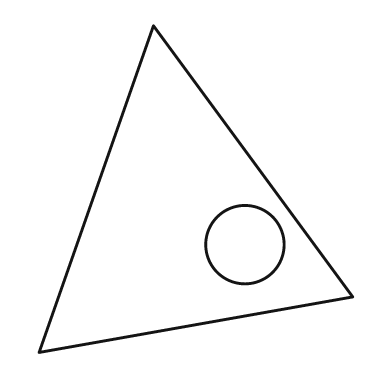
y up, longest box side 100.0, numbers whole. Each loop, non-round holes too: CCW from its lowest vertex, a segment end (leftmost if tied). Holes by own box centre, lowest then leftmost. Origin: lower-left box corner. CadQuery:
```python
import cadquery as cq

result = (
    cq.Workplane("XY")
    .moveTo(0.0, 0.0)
    .lineTo(96.0, 17.0)
    .lineTo(35.0, 100.0)
    .close()
    .moveTo(63.0, 33.0)
    .circle(12.0)
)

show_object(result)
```